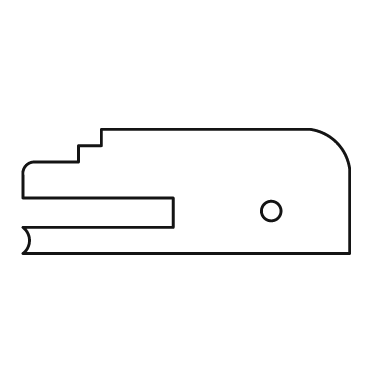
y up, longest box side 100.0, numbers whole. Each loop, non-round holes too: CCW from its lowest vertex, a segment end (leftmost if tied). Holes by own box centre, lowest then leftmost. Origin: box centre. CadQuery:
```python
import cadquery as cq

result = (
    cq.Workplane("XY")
    .moveTo(-50.0, -19.0)
    .lineTo(50.0, -19.0)
    .lineTo(50.0, 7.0)
    .threePointArc((46.0, 15.0), (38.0, 19.0))
    .lineTo(-26.0, 19.0)
    .lineTo(-26.0, 14.0)
    .lineTo(-33.0, 14.0)
    .lineTo(-33.0, 9.0)
    .lineTo(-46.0, 9.0)
    .threePointArc((-49.0, 8.0), (-50.0, 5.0))
    .lineTo(-50.0, -2.0)
    .lineTo(-4.0, -2.0)
    .lineTo(-4.0, -11.0)
    .lineTo(-50.0, -11.0)
    .threePointArc((-48.0, -15.0), (-50.0, -19.0))
    .close()
    .moveTo(26.0, -6.0)
    .circle(3.0)
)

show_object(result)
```